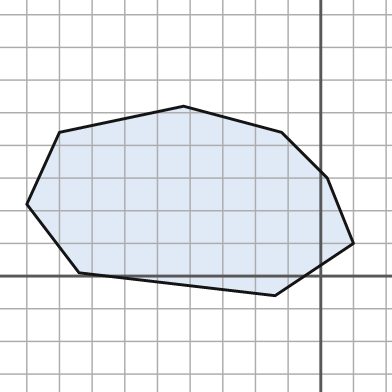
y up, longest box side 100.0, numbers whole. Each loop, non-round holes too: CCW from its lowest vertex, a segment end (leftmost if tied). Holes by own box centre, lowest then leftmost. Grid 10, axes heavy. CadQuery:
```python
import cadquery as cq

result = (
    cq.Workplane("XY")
    .moveTo(-14.0, -6.0)
    .lineTo(10.0, 10.0)
    .lineTo(2.0, 30.0)
    .lineTo(-12.0, 44.0)
    .lineTo(-42.0, 52.0)
    .lineTo(-80.0, 44.0)
    .lineTo(-90.0, 22.0)
    .lineTo(-74.0, 1.0)
    .close()
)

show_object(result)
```